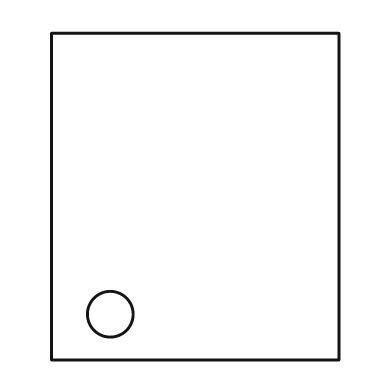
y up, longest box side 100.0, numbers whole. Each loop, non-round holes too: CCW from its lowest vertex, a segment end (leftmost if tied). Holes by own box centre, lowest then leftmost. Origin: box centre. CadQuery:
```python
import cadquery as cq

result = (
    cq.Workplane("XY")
    .moveTo(-44.0, -50.0)
    .lineTo(44.0, -50.0)
    .lineTo(44.0, 50.0)
    .lineTo(-44.0, 50.0)
    .close()
    .moveTo(-26.0, -36.0)
    .circle(7.0)
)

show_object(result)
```